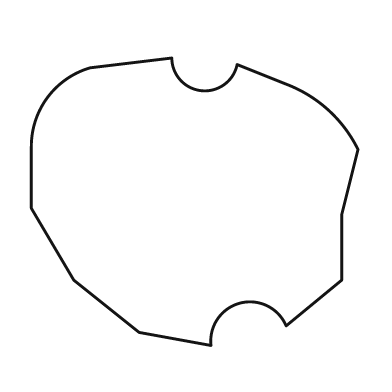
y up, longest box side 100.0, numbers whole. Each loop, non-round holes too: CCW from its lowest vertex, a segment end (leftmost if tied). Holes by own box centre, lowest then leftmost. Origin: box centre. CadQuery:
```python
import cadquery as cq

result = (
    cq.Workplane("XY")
    .moveTo(5.0, -44.0)
    .threePointArc((14.0, -31.0), (28.0, -38.0))
    .lineTo(45.0, -24.0)
    .lineTo(45.0, -4.0)
    .lineTo(50.0, 16.0)
    .threePointArc((41.0, 28.0), (28.0, 36.0))
    .lineTo(13.0, 42.0)
    .threePointArc((2.0, 34.0), (-7.0, 44.0))
    .lineTo(-32.0, 41.0)
    .threePointArc((-45.0, 32.0), (-50.0, 17.0))
    .lineTo(-50.0, -2.0)
    .lineTo(-37.0, -24.0)
    .lineTo(-17.0, -40.0)
    .close()
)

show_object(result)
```